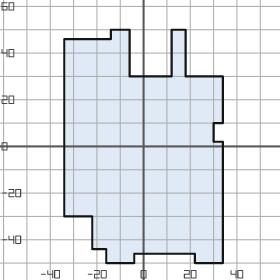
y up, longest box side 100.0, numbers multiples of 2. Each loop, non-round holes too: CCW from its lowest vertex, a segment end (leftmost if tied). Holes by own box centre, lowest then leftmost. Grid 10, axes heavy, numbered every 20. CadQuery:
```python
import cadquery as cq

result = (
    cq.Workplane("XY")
    .moveTo(-16.0, -50.0)
    .lineTo(-4.0, -50.0)
    .lineTo(-4.0, -46.0)
    .lineTo(22.0, -46.0)
    .lineTo(22.0, -50.0)
    .lineTo(34.0, -50.0)
    .lineTo(34.0, 2.0)
    .lineTo(30.0, 2.0)
    .lineTo(30.0, 10.0)
    .lineTo(34.0, 10.0)
    .lineTo(34.0, 30.0)
    .lineTo(18.0, 30.0)
    .lineTo(18.0, 50.0)
    .lineTo(12.0, 50.0)
    .lineTo(12.0, 30.0)
    .lineTo(-6.0, 30.0)
    .lineTo(-6.0, 50.0)
    .lineTo(-14.0, 50.0)
    .lineTo(-14.0, 46.0)
    .lineTo(-34.0, 46.0)
    .lineTo(-34.0, -30.0)
    .lineTo(-22.0, -30.0)
    .lineTo(-22.0, -44.0)
    .lineTo(-16.0, -44.0)
    .close()
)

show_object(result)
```